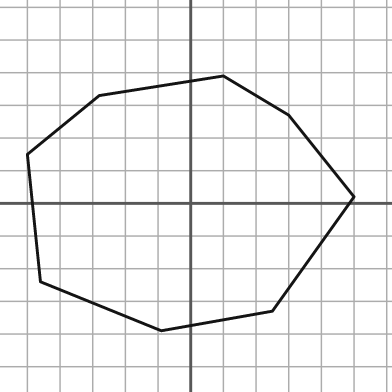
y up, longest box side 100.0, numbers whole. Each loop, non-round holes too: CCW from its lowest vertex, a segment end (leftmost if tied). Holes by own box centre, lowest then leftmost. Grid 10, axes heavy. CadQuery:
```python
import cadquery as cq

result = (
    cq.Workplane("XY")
    .moveTo(-9.0, -39.0)
    .lineTo(25.0, -33.0)
    .lineTo(50.0, 2.0)
    .lineTo(30.0, 27.0)
    .lineTo(10.0, 39.0)
    .lineTo(-28.0, 33.0)
    .lineTo(-50.0, 15.0)
    .lineTo(-46.0, -24.0)
    .close()
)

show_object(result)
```